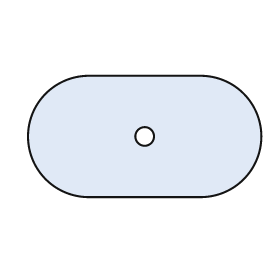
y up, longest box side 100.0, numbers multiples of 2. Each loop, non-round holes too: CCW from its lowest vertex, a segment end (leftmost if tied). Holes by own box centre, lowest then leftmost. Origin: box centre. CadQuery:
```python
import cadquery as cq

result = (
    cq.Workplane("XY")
    .moveTo(-24.0, -26.0)
    .lineTo(24.0, -26.0)
    .threePointArc((50.0, 0.0), (24.0, 26.0))
    .lineTo(-24.0, 26.0)
    .threePointArc((-50.0, 0.0), (-24.0, -26.0))
    .close()
    .moveTo(0.0, 0.0)
    .circle(4.0)
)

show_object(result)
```